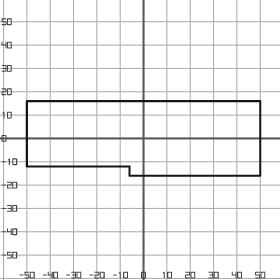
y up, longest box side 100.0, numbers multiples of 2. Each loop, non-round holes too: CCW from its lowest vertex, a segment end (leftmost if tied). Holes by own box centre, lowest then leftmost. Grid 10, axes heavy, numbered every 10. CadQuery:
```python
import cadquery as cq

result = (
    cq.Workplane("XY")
    .moveTo(-6.0, -16.0)
    .lineTo(50.0, -16.0)
    .lineTo(50.0, 16.0)
    .lineTo(-50.0, 16.0)
    .lineTo(-50.0, -12.0)
    .lineTo(-6.0, -12.0)
    .close()
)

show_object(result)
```